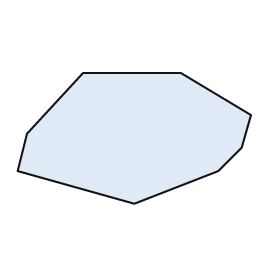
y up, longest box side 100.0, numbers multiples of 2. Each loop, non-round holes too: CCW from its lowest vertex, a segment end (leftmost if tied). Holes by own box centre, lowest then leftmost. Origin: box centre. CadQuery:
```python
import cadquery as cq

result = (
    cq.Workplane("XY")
    .moveTo(0.0, -28.0)
    .lineTo(36.0, -14.0)
    .lineTo(46.0, -4.0)
    .lineTo(50.0, 10.0)
    .lineTo(20.0, 28.0)
    .lineTo(-22.0, 28.0)
    .lineTo(-46.0, 2.0)
    .lineTo(-50.0, -14.0)
    .close()
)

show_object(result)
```